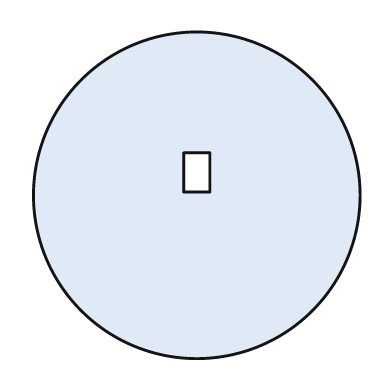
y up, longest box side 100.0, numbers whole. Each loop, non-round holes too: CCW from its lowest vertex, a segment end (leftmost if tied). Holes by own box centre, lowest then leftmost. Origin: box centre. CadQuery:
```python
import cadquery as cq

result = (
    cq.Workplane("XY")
    .moveTo(0.0, 0.0)
    .circle(50.0)
    .moveTo(-4.0, 1.0)
    .lineTo(4.0, 1.0)
    .lineTo(4.0, 13.0)
    .lineTo(-4.0, 13.0)
    .close()
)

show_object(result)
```